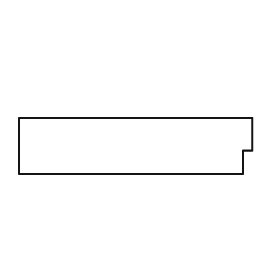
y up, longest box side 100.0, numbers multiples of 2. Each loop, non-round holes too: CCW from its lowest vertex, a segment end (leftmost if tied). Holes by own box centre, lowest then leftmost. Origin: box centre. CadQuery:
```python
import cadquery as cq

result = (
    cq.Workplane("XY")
    .moveTo(-50.0, -12.0)
    .lineTo(46.0, -12.0)
    .lineTo(46.0, -2.0)
    .lineTo(50.0, -2.0)
    .lineTo(50.0, 12.0)
    .lineTo(-50.0, 12.0)
    .close()
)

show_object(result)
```